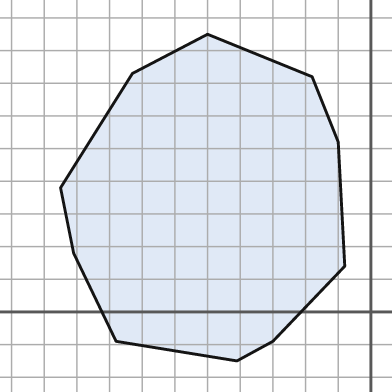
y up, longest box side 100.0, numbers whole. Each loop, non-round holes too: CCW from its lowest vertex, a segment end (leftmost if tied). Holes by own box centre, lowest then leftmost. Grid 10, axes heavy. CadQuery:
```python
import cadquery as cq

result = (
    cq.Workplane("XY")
    .moveTo(-41.0, -15.0)
    .lineTo(-30.0, -9.0)
    .lineTo(-8.0, 14.0)
    .lineTo(-10.0, 52.0)
    .lineTo(-18.0, 72.0)
    .lineTo(-50.0, 85.0)
    .lineTo(-73.0, 73.0)
    .lineTo(-95.0, 38.0)
    .lineTo(-91.0, 18.0)
    .lineTo(-78.0, -9.0)
    .close()
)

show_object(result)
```